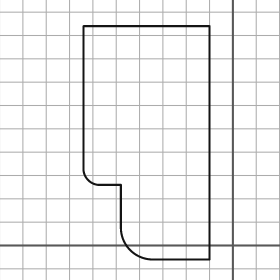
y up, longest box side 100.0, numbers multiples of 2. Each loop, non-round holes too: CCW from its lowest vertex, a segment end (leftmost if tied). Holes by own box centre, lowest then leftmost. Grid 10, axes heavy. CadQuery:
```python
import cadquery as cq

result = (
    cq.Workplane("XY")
    .moveTo(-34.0, -6.0)
    .lineTo(-10.0, -6.0)
    .lineTo(-10.0, 94.0)
    .lineTo(-64.0, 94.0)
    .lineTo(-64.0, 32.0)
    .threePointArc((-62.0, 28.0), (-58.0, 26.0))
    .lineTo(-48.0, 26.0)
    .lineTo(-48.0, 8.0)
    .threePointArc((-44.0, -2.0), (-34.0, -6.0))
    .close()
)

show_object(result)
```